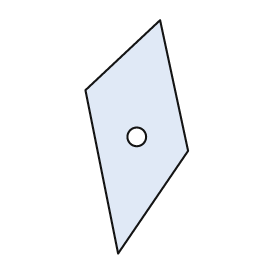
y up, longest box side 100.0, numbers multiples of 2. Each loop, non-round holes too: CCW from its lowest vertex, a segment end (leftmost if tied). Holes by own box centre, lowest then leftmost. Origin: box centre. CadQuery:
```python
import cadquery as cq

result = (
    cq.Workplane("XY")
    .moveTo(-8.0, -50.0)
    .lineTo(22.0, -6.0)
    .lineTo(10.0, 50.0)
    .lineTo(-22.0, 20.0)
    .close()
    .moveTo(0.0, 0.0)
    .circle(4.0)
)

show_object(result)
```